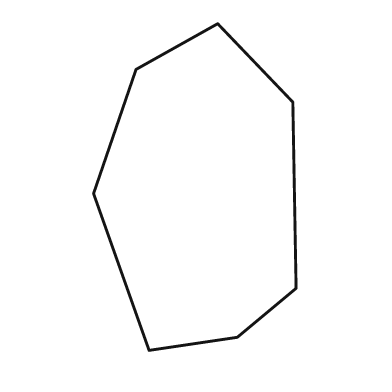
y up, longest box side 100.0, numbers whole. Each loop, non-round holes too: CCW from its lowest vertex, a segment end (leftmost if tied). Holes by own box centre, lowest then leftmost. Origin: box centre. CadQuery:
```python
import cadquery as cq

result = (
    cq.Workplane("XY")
    .moveTo(-14.0, -50.0)
    .lineTo(13.0, -46.0)
    .lineTo(31.0, -31.0)
    .lineTo(30.0, 26.0)
    .lineTo(7.0, 50.0)
    .lineTo(-18.0, 36.0)
    .lineTo(-31.0, -2.0)
    .close()
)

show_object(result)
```